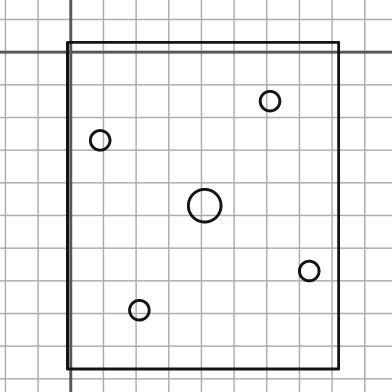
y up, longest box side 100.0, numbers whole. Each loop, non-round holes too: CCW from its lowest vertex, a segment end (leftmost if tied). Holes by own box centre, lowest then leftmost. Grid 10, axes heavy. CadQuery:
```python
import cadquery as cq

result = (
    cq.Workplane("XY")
    .moveTo(-1.0, -97.0)
    .lineTo(82.0, -97.0)
    .lineTo(82.0, 3.0)
    .lineTo(-1.0, 3.0)
    .close()
    .moveTo(21.0, -79.0)
    .circle(3.0)
    .moveTo(73.0, -67.0)
    .circle(3.0)
    .moveTo(41.0, -47.0)
    .circle(5.0)
    .moveTo(9.0, -27.0)
    .circle(3.0)
    .moveTo(61.0, -15.0)
    .circle(3.0)
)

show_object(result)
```